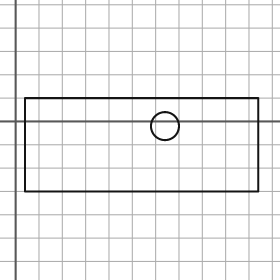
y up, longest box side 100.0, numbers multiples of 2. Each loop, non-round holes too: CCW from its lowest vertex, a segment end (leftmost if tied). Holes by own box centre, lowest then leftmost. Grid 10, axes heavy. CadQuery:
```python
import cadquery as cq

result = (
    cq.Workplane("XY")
    .moveTo(4.0, -30.0)
    .lineTo(104.0, -30.0)
    .lineTo(104.0, 10.0)
    .lineTo(4.0, 10.0)
    .close()
    .moveTo(64.0, -2.0)
    .circle(6.0)
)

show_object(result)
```